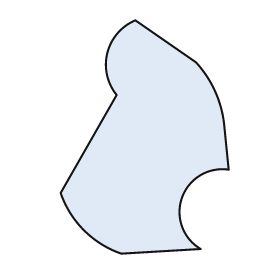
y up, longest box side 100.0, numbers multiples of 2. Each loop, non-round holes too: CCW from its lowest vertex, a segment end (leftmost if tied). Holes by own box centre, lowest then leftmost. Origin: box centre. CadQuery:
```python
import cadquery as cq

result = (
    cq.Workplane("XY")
    .moveTo(-10.0, -50.0)
    .lineTo(24.0, -48.0)
    .threePointArc((16.0, -26.0), (36.0, -14.0))
    .lineTo(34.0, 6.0)
    .threePointArc((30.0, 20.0), (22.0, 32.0))
    .lineTo(-4.0, 50.0)
    .threePointArc((-16.0, 36.0), (-12.0, 18.0))
    .lineTo(-36.0, -24.0)
    .threePointArc((-26.0, -40.0), (-10.0, -50.0))
    .close()
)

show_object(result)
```